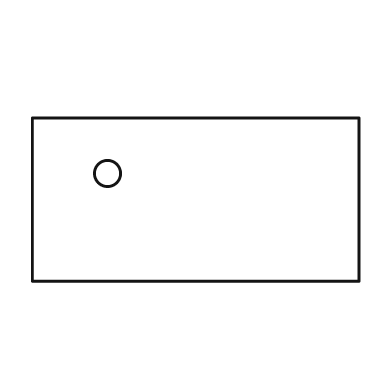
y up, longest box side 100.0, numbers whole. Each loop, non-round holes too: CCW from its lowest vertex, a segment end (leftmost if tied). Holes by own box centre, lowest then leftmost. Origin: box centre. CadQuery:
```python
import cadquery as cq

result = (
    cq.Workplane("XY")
    .moveTo(-50.0, -25.0)
    .lineTo(50.0, -25.0)
    .lineTo(50.0, 25.0)
    .lineTo(-50.0, 25.0)
    .close()
    .moveTo(-27.0, 8.0)
    .circle(4.0)
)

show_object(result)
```